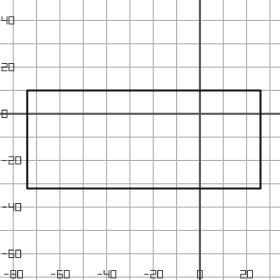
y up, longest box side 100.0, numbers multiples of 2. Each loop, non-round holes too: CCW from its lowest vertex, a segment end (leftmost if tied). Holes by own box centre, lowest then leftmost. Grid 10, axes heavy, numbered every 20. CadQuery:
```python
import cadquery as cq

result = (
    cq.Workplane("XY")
    .moveTo(-74.0, -32.0)
    .lineTo(26.0, -32.0)
    .lineTo(26.0, 10.0)
    .lineTo(-74.0, 10.0)
    .close()
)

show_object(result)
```